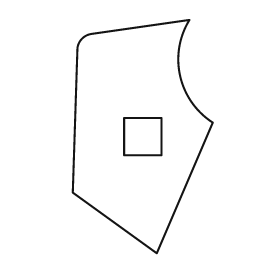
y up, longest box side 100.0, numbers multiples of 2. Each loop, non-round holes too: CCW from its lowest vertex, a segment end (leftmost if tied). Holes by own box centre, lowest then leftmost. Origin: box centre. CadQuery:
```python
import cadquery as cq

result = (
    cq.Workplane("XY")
    .moveTo(6.0, -50.0)
    .lineTo(30.0, 6.0)
    .threePointArc((16.0, 26.0), (20.0, 50.0))
    .lineTo(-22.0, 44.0)
    .threePointArc((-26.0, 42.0), (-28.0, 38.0))
    .lineTo(-30.0, -24.0)
    .close()
    .moveTo(-8.0, -8.0)
    .lineTo(8.0, -8.0)
    .lineTo(8.0, 8.0)
    .lineTo(-8.0, 8.0)
    .close()
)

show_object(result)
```